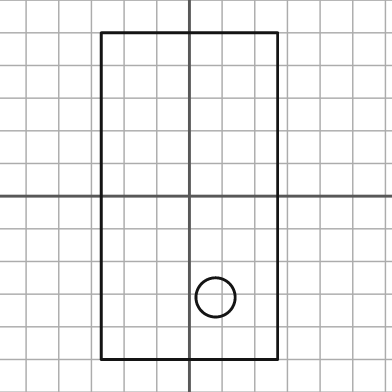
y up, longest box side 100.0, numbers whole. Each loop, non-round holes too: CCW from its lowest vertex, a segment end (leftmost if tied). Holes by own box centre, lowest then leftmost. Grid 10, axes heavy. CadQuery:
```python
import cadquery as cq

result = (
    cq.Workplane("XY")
    .moveTo(-27.0, -50.0)
    .lineTo(27.0, -50.0)
    .lineTo(27.0, 50.0)
    .lineTo(-27.0, 50.0)
    .close()
    .moveTo(8.0, -31.0)
    .circle(6.0)
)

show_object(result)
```